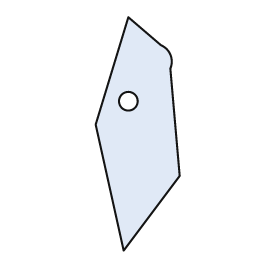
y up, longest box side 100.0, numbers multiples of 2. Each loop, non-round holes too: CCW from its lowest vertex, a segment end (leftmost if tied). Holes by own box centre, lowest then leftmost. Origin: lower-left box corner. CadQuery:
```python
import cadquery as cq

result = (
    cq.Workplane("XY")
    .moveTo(12.0, 0.0)
    .lineTo(36.0, 32.0)
    .lineTo(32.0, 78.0)
    .threePointArc((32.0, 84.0), (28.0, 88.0))
    .lineTo(14.0, 100.0)
    .lineTo(0.0, 54.0)
    .close()
    .moveTo(14.0, 64.0)
    .circle(4.0)
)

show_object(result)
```